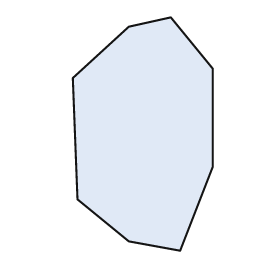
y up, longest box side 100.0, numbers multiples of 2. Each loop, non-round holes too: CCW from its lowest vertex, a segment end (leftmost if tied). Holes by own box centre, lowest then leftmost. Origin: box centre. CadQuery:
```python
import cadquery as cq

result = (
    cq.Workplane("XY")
    .moveTo(16.0, -50.0)
    .lineTo(30.0, -14.0)
    .lineTo(30.0, 28.0)
    .lineTo(12.0, 50.0)
    .lineTo(-6.0, 46.0)
    .lineTo(-30.0, 24.0)
    .lineTo(-28.0, -28.0)
    .lineTo(-6.0, -46.0)
    .close()
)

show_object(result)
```